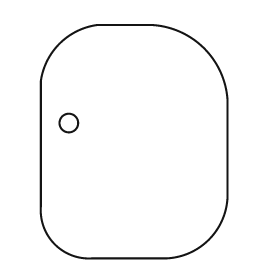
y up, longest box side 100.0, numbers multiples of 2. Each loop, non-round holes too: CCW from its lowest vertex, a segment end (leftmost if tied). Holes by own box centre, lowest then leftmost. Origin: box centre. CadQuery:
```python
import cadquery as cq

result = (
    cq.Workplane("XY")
    .moveTo(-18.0, -50.0)
    .lineTo(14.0, -50.0)
    .threePointArc((32.0, -42.0), (40.0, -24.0))
    .lineTo(40.0, 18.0)
    .threePointArc((30.0, 40.0), (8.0, 50.0))
    .lineTo(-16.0, 50.0)
    .threePointArc((-32.0, 42.0), (-40.0, 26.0))
    .lineTo(-40.0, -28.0)
    .threePointArc((-34.0, -44.0), (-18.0, -50.0))
    .close()
    .moveTo(-28.0, 8.0)
    .circle(4.0)
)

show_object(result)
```